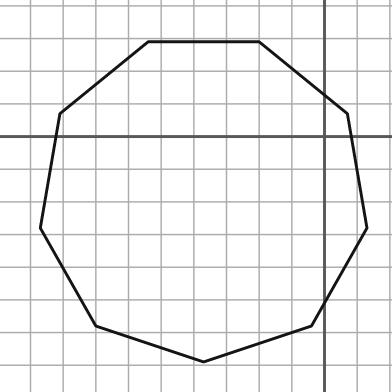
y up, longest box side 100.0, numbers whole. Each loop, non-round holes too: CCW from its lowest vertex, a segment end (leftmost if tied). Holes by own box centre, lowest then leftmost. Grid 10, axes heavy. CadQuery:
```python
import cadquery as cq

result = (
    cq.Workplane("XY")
    .moveTo(-37.0, -69.0)
    .lineTo(-4.0, -58.0)
    .lineTo(13.0, -28.0)
    .lineTo(7.0, 7.0)
    .lineTo(-20.0, 29.0)
    .lineTo(-54.0, 29.0)
    .lineTo(-81.0, 7.0)
    .lineTo(-87.0, -28.0)
    .lineTo(-70.0, -58.0)
    .close()
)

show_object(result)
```